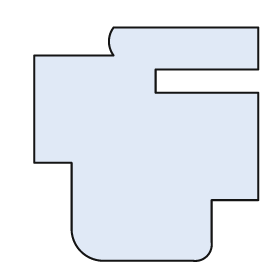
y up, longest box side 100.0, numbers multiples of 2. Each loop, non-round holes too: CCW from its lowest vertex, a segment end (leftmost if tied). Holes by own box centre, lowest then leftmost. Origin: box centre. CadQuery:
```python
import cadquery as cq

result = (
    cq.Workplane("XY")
    .moveTo(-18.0, -50.0)
    .lineTo(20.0, -50.0)
    .threePointArc((26.0, -48.0), (28.0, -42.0))
    .lineTo(28.0, -24.0)
    .lineTo(48.0, -24.0)
    .lineTo(48.0, 22.0)
    .lineTo(4.0, 22.0)
    .lineTo(4.0, 32.0)
    .lineTo(48.0, 32.0)
    .lineTo(48.0, 50.0)
    .lineTo(-14.0, 50.0)
    .threePointArc((-16.0, 44.0), (-14.0, 38.0))
    .lineTo(-48.0, 38.0)
    .lineTo(-48.0, -8.0)
    .lineTo(-32.0, -8.0)
    .lineTo(-32.0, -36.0)
    .threePointArc((-28.0, -46.0), (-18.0, -50.0))
    .close()
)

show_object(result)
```